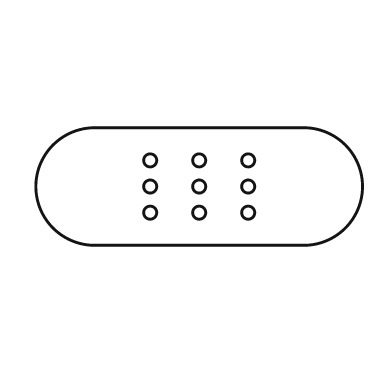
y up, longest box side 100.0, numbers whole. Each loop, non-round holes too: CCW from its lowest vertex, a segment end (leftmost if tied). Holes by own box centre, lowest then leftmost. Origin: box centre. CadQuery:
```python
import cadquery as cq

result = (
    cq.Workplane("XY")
    .moveTo(-32.0, -18.0)
    .lineTo(32.0, -18.0)
    .threePointArc((50.0, 0.0), (32.0, 18.0))
    .lineTo(-32.0, 18.0)
    .threePointArc((-50.0, 0.0), (-32.0, -18.0))
    .close()
    .moveTo(-15.0, -8.0)
    .circle(2.0)
    .moveTo(0.0, -8.0)
    .circle(2.0)
    .moveTo(15.0, -8.0)
    .circle(2.0)
    .moveTo(-15.0, 0.0)
    .circle(2.0)
    .moveTo(0.0, 0.0)
    .circle(2.0)
    .moveTo(15.0, 0.0)
    .circle(2.0)
    .moveTo(-15.0, 8.0)
    .circle(2.0)
    .moveTo(0.0, 8.0)
    .circle(2.0)
    .moveTo(15.0, 8.0)
    .circle(2.0)
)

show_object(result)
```